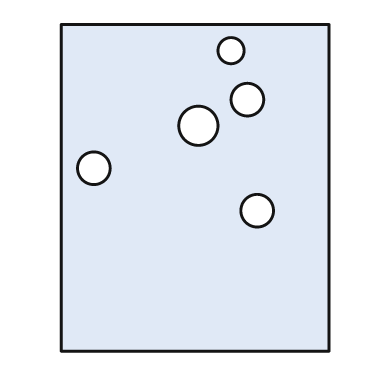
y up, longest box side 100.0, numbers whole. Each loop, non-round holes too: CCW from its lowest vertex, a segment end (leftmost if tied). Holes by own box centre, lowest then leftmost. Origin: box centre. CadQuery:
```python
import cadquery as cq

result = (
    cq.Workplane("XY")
    .moveTo(-41.0, -50.0)
    .lineTo(41.0, -50.0)
    .lineTo(41.0, 50.0)
    .lineTo(-41.0, 50.0)
    .close()
    .moveTo(19.0, -7.0)
    .circle(5.0)
    .moveTo(-31.0, 6.0)
    .circle(5.0)
    .moveTo(1.0, 19.0)
    .circle(6.0)
    .moveTo(16.0, 27.0)
    .circle(5.0)
    .moveTo(11.0, 42.0)
    .circle(4.0)
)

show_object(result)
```